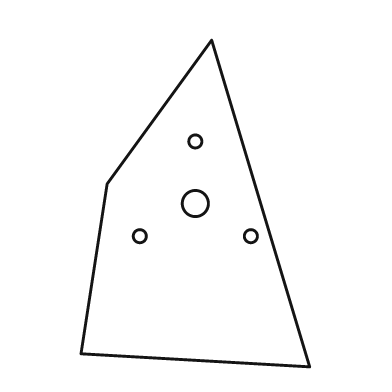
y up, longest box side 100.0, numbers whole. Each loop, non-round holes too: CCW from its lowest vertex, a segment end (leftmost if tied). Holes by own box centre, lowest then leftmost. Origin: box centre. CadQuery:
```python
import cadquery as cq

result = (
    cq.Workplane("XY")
    .moveTo(35.0, -50.0)
    .lineTo(5.0, 50.0)
    .lineTo(-27.0, 6.0)
    .lineTo(-35.0, -46.0)
    .close()
    .moveTo(-17.0, -10.0)
    .circle(2.0)
    .moveTo(17.0, -10.0)
    .circle(2.0)
    .moveTo(0.0, 0.0)
    .circle(4.0)
    .moveTo(0.0, 19.0)
    .circle(2.0)
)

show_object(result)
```